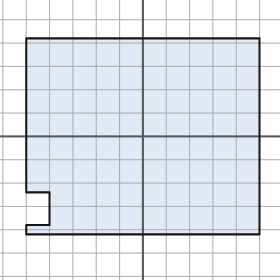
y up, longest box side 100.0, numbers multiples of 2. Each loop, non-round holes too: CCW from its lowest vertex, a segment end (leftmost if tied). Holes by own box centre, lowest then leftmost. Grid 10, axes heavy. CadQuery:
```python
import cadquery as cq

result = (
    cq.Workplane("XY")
    .moveTo(-50.0, -42.0)
    .lineTo(50.0, -42.0)
    .lineTo(50.0, 42.0)
    .lineTo(-50.0, 42.0)
    .lineTo(-50.0, -24.0)
    .lineTo(-40.0, -24.0)
    .lineTo(-40.0, -38.0)
    .lineTo(-50.0, -38.0)
    .close()
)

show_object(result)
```